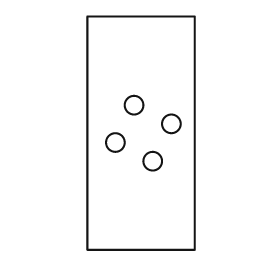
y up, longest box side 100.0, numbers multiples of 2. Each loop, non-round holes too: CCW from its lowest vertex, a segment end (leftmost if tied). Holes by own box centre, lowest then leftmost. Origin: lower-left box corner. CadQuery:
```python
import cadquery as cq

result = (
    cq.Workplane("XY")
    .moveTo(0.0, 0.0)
    .lineTo(46.0, 0.0)
    .lineTo(46.0, 100.0)
    .lineTo(0.0, 100.0)
    .close()
    .moveTo(28.0, 38.0)
    .circle(4.0)
    .moveTo(12.0, 46.0)
    .circle(4.0)
    .moveTo(36.0, 54.0)
    .circle(4.0)
    .moveTo(20.0, 62.0)
    .circle(4.0)
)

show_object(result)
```